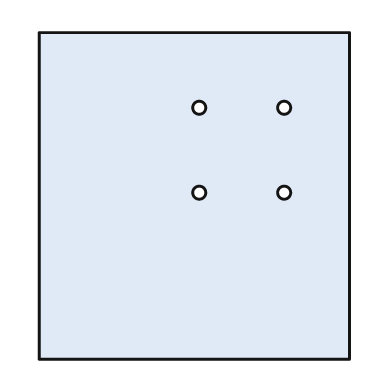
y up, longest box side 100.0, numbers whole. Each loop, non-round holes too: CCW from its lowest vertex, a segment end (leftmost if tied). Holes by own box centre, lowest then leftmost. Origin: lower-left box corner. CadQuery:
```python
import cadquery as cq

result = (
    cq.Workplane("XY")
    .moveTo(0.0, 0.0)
    .lineTo(95.0, 0.0)
    .lineTo(95.0, 100.0)
    .lineTo(0.0, 100.0)
    .close()
    .moveTo(49.0, 51.0)
    .circle(2.0)
    .moveTo(75.0, 51.0)
    .circle(2.0)
    .moveTo(49.0, 77.0)
    .circle(2.0)
    .moveTo(75.0, 77.0)
    .circle(2.0)
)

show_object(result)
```